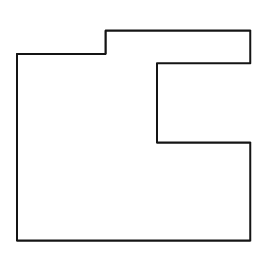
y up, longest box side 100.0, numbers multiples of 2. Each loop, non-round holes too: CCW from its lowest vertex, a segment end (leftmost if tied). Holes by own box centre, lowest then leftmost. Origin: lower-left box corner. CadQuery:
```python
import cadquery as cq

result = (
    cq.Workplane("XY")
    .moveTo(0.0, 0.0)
    .lineTo(100.0, 0.0)
    .lineTo(100.0, 42.0)
    .lineTo(60.0, 42.0)
    .lineTo(60.0, 76.0)
    .lineTo(100.0, 76.0)
    .lineTo(100.0, 90.0)
    .lineTo(38.0, 90.0)
    .lineTo(38.0, 80.0)
    .lineTo(0.0, 80.0)
    .close()
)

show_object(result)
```